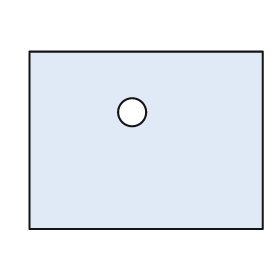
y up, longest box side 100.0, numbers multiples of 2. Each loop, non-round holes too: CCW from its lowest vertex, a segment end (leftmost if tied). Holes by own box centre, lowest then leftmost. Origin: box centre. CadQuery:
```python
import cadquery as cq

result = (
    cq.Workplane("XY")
    .moveTo(-50.0, -38.0)
    .lineTo(50.0, -38.0)
    .lineTo(50.0, 38.0)
    .lineTo(-50.0, 38.0)
    .close()
    .moveTo(-6.0, 12.0)
    .circle(6.0)
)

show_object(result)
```